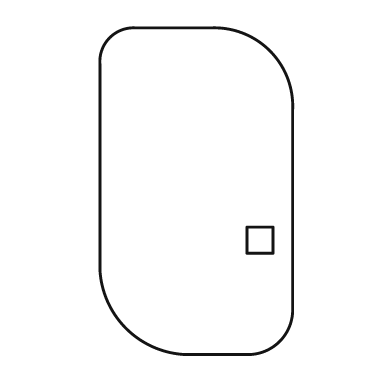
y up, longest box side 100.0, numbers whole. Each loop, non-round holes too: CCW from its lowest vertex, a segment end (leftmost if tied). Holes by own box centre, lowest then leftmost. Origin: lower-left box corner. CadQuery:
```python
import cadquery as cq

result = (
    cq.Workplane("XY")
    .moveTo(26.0, 0.0)
    .lineTo(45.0, 0.0)
    .threePointArc((55.0, 4.0), (59.0, 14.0))
    .lineTo(59.0, 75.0)
    .threePointArc((52.0, 93.0), (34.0, 100.0))
    .lineTo(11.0, 100.0)
    .threePointArc((3.0, 97.0), (0.0, 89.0))
    .lineTo(0.0, 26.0)
    .threePointArc((8.0, 8.0), (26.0, 0.0))
    .close()
    .moveTo(45.0, 31.0)
    .lineTo(53.0, 31.0)
    .lineTo(53.0, 39.0)
    .lineTo(45.0, 39.0)
    .close()
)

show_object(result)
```